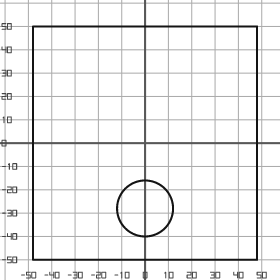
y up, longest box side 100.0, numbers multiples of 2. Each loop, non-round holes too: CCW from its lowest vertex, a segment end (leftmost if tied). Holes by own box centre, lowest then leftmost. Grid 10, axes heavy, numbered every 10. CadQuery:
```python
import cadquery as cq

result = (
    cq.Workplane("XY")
    .moveTo(-48.0, -50.0)
    .lineTo(48.0, -50.0)
    .lineTo(48.0, 50.0)
    .lineTo(-48.0, 50.0)
    .close()
    .moveTo(0.0, -28.0)
    .circle(12.0)
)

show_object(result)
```